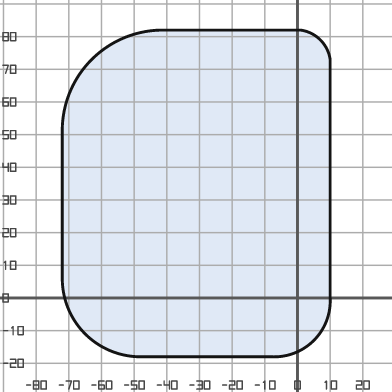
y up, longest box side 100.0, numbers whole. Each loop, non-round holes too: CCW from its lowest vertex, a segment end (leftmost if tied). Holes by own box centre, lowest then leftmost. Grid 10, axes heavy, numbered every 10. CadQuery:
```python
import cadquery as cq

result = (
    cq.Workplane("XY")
    .moveTo(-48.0, -18.0)
    .lineTo(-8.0, -18.0)
    .threePointArc((5.0, -13.0), (10.0, 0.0))
    .lineTo(10.0, 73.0)
    .threePointArc((7.0, 79.0), (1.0, 82.0))
    .lineTo(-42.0, 82.0)
    .threePointArc((-63.0, 73.0), (-72.0, 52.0))
    .lineTo(-72.0, 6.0)
    .threePointArc((-65.0, -11.0), (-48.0, -18.0))
    .close()
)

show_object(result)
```